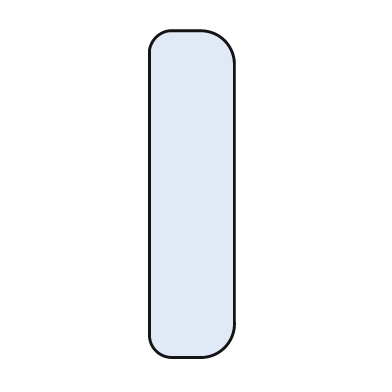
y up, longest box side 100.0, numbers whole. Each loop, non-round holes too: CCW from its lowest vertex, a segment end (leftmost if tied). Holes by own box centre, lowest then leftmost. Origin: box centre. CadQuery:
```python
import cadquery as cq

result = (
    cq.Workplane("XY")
    .moveTo(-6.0, -50.0)
    .lineTo(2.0, -50.0)
    .threePointArc((10.0, -47.0), (13.0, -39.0))
    .lineTo(13.0, 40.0)
    .threePointArc((10.0, 47.0), (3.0, 50.0))
    .lineTo(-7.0, 50.0)
    .threePointArc((-11.0, 48.0), (-13.0, 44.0))
    .lineTo(-13.0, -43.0)
    .threePointArc((-11.0, -48.0), (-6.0, -50.0))
    .close()
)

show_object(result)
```